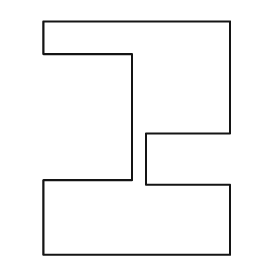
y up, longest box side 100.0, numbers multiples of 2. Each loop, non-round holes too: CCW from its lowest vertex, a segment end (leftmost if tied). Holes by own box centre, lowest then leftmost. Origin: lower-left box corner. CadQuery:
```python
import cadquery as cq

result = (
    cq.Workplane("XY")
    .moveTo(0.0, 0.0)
    .lineTo(80.0, 0.0)
    .lineTo(80.0, 30.0)
    .lineTo(44.0, 30.0)
    .lineTo(44.0, 52.0)
    .lineTo(80.0, 52.0)
    .lineTo(80.0, 100.0)
    .lineTo(0.0, 100.0)
    .lineTo(0.0, 86.0)
    .lineTo(38.0, 86.0)
    .lineTo(38.0, 32.0)
    .lineTo(0.0, 32.0)
    .close()
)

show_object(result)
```